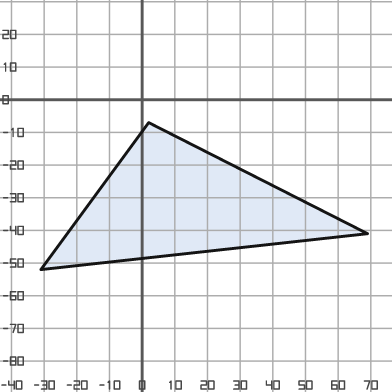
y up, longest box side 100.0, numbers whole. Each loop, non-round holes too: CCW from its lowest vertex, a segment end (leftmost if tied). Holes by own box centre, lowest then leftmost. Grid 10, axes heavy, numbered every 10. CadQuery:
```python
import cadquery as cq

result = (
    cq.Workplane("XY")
    .moveTo(-31.0, -52.0)
    .lineTo(69.0, -41.0)
    .lineTo(2.0, -7.0)
    .close()
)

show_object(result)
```